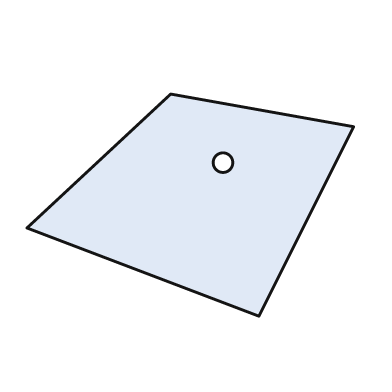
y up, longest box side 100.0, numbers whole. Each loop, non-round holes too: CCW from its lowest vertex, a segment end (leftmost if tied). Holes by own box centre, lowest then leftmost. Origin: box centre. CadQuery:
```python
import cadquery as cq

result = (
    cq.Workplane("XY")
    .moveTo(21.0, -34.0)
    .lineTo(50.0, 24.0)
    .lineTo(-6.0, 34.0)
    .lineTo(-50.0, -7.0)
    .close()
    .moveTo(10.0, 13.0)
    .circle(3.0)
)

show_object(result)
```